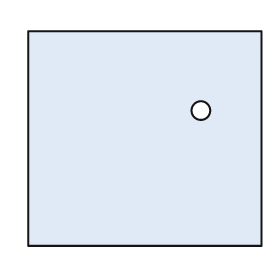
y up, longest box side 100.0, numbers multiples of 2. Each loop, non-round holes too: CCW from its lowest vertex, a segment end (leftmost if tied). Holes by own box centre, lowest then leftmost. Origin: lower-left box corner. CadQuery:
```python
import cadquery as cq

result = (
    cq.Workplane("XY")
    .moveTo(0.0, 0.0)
    .lineTo(100.0, 0.0)
    .lineTo(100.0, 92.0)
    .lineTo(0.0, 92.0)
    .close()
    .moveTo(74.0, 58.0)
    .circle(4.0)
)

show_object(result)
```